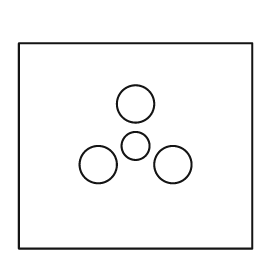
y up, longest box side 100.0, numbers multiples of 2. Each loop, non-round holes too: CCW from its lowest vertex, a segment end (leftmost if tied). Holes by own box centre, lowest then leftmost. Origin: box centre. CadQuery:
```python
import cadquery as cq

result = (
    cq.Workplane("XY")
    .moveTo(-50.0, -44.0)
    .lineTo(50.0, -44.0)
    .lineTo(50.0, 44.0)
    .lineTo(-50.0, 44.0)
    .close()
    .moveTo(-16.0, -8.0)
    .circle(8.0)
    .moveTo(16.0, -8.0)
    .circle(8.0)
    .moveTo(0.0, 0.0)
    .circle(6.0)
    .moveTo(0.0, 18.0)
    .circle(8.0)
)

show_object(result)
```